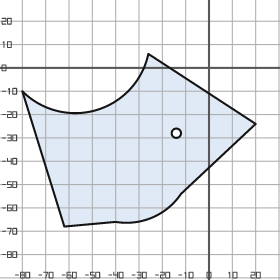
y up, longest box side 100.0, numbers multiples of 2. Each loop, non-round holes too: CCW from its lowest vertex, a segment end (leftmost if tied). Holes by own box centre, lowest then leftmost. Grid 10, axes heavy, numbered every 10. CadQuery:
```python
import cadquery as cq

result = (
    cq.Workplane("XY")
    .moveTo(-62.0, -68.0)
    .lineTo(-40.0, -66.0)
    .threePointArc((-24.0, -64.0), (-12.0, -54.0))
    .lineTo(20.0, -24.0)
    .lineTo(-26.0, 6.0)
    .threePointArc((-48.0, -18.0), (-80.0, -10.0))
    .close()
    .moveTo(-14.0, -28.0)
    .circle(2.0)
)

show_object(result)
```